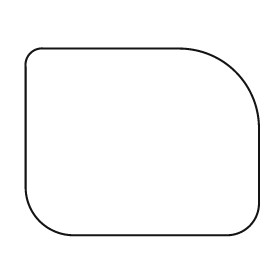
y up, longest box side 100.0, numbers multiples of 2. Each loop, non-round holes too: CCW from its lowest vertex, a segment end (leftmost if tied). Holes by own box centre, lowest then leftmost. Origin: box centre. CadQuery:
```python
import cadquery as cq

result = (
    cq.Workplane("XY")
    .moveTo(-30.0, -40.0)
    .lineTo(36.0, -40.0)
    .threePointArc((46.0, -36.0), (50.0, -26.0))
    .lineTo(50.0, 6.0)
    .threePointArc((40.0, 30.0), (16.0, 40.0))
    .lineTo(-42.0, 40.0)
    .threePointArc((-48.0, 38.0), (-50.0, 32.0))
    .lineTo(-50.0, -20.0)
    .threePointArc((-44.0, -34.0), (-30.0, -40.0))
    .close()
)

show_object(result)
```